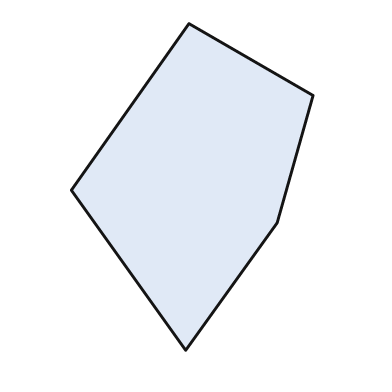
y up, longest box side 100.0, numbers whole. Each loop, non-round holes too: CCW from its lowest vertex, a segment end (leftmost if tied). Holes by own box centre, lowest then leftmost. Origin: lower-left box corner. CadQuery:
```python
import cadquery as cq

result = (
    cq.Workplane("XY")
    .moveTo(35.0, 0.0)
    .lineTo(63.0, 39.0)
    .lineTo(74.0, 78.0)
    .lineTo(36.0, 100.0)
    .lineTo(0.0, 49.0)
    .close()
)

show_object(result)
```